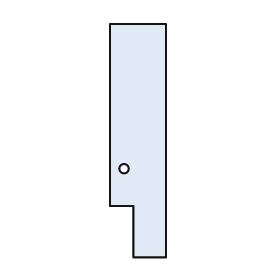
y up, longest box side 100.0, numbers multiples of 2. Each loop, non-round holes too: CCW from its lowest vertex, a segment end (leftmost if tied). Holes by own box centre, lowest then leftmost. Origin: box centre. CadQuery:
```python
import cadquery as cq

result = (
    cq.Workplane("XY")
    .moveTo(-2.0, -50.0)
    .lineTo(12.0, -50.0)
    .lineTo(12.0, 50.0)
    .lineTo(-12.0, 50.0)
    .lineTo(-12.0, -28.0)
    .lineTo(-2.0, -28.0)
    .close()
    .moveTo(-6.0, -12.0)
    .circle(2.0)
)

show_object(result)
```